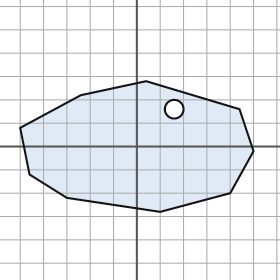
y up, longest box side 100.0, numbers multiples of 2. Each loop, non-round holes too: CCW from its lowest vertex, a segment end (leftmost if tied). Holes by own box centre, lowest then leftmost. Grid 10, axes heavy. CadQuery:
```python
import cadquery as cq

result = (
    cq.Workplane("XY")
    .moveTo(10.0, -28.0)
    .lineTo(40.0, -20.0)
    .lineTo(50.0, -2.0)
    .lineTo(44.0, 16.0)
    .lineTo(4.0, 28.0)
    .lineTo(-24.0, 22.0)
    .lineTo(-50.0, 8.0)
    .lineTo(-46.0, -12.0)
    .lineTo(-30.0, -22.0)
    .close()
    .moveTo(16.0, 16.0)
    .circle(4.0)
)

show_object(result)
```